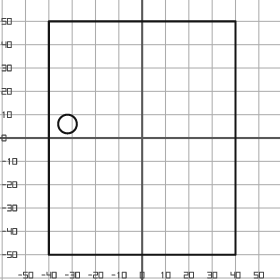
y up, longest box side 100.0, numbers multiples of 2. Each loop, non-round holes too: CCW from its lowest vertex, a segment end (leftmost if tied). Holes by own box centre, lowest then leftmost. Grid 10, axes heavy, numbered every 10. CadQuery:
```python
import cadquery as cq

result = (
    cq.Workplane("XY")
    .moveTo(-40.0, -50.0)
    .lineTo(40.0, -50.0)
    .lineTo(40.0, 50.0)
    .lineTo(-40.0, 50.0)
    .close()
    .moveTo(-32.0, 6.0)
    .circle(4.0)
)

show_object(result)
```